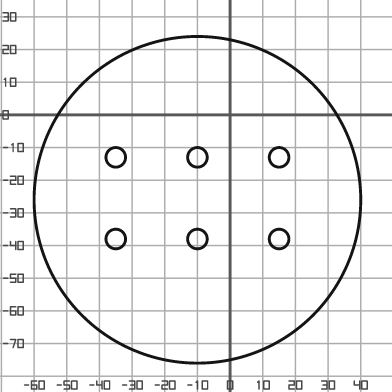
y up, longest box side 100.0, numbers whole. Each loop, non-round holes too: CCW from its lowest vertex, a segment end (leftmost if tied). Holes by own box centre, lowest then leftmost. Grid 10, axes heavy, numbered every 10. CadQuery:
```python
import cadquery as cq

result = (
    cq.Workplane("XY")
    .moveTo(-10.0, -26.0)
    .circle(50.0)
    .moveTo(-35.0, -38.0)
    .circle(3.0)
    .moveTo(-10.0, -38.0)
    .circle(3.0)
    .moveTo(15.0, -38.0)
    .circle(3.0)
    .moveTo(-35.0, -13.0)
    .circle(3.0)
    .moveTo(-10.0, -13.0)
    .circle(3.0)
    .moveTo(15.0, -13.0)
    .circle(3.0)
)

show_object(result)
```